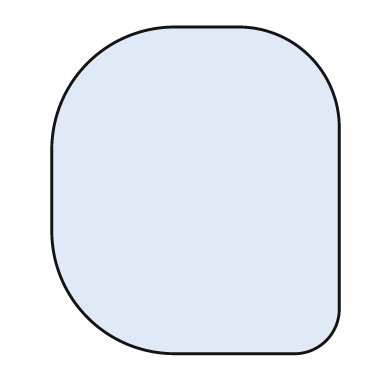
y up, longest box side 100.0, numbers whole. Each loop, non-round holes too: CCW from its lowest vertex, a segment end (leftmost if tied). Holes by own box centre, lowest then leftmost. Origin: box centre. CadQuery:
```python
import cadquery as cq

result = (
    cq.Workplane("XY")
    .moveTo(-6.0, -50.0)
    .lineTo(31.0, -50.0)
    .threePointArc((40.0, -46.0), (44.0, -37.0))
    .lineTo(44.0, 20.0)
    .threePointArc((35.0, 41.0), (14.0, 50.0))
    .lineTo(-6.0, 50.0)
    .threePointArc((-33.0, 39.0), (-44.0, 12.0))
    .lineTo(-44.0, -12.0)
    .threePointArc((-33.0, -39.0), (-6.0, -50.0))
    .close()
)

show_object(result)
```